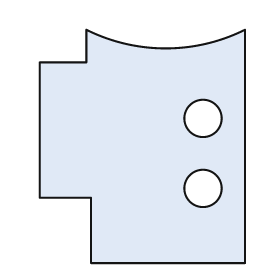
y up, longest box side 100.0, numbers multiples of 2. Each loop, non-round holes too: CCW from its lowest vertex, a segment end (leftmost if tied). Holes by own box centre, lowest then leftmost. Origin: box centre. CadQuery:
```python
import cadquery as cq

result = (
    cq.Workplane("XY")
    .moveTo(-22.0, -50.0)
    .lineTo(44.0, -50.0)
    .lineTo(44.0, 50.0)
    .threePointArc((10.0, 42.0), (-24.0, 50.0))
    .lineTo(-24.0, 36.0)
    .lineTo(-44.0, 36.0)
    .lineTo(-44.0, -22.0)
    .lineTo(-22.0, -22.0)
    .close()
    .moveTo(26.0, -18.0)
    .circle(8.0)
    .moveTo(26.0, 12.0)
    .circle(8.0)
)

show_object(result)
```